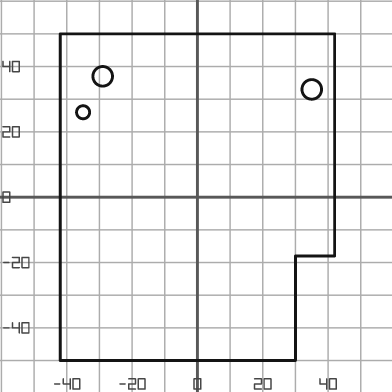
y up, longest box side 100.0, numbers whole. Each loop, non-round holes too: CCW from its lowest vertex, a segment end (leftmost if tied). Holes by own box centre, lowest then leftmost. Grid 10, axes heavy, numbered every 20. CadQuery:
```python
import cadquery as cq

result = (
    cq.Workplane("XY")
    .moveTo(-42.0, -50.0)
    .lineTo(30.0, -50.0)
    .lineTo(30.0, -18.0)
    .lineTo(42.0, -18.0)
    .lineTo(42.0, 50.0)
    .lineTo(-42.0, 50.0)
    .close()
    .moveTo(-35.0, 26.0)
    .circle(2.0)
    .moveTo(35.0, 33.0)
    .circle(3.0)
    .moveTo(-29.0, 37.0)
    .circle(3.0)
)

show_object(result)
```